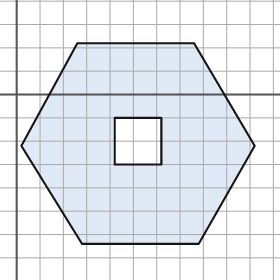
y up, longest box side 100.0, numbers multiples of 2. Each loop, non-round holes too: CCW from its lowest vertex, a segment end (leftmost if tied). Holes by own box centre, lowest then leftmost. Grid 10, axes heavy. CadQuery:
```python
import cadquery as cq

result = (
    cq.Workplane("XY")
    .moveTo(28.0, -64.0)
    .lineTo(78.0, -64.0)
    .lineTo(102.0, -22.0)
    .lineTo(76.0, 22.0)
    .lineTo(26.0, 22.0)
    .lineTo(2.0, -22.0)
    .close()
    .moveTo(42.0, -30.0)
    .lineTo(62.0, -30.0)
    .lineTo(62.0, -10.0)
    .lineTo(42.0, -10.0)
    .close()
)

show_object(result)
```